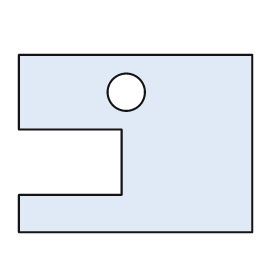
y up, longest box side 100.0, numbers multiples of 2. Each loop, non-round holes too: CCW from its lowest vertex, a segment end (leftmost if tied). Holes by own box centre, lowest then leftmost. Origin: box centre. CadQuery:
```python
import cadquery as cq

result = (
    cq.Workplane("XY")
    .moveTo(-50.0, -38.0)
    .lineTo(50.0, -38.0)
    .lineTo(50.0, 38.0)
    .lineTo(-50.0, 38.0)
    .lineTo(-50.0, 6.0)
    .lineTo(-6.0, 6.0)
    .lineTo(-6.0, -22.0)
    .lineTo(-50.0, -22.0)
    .close()
    .moveTo(-4.0, 22.0)
    .circle(8.0)
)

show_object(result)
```